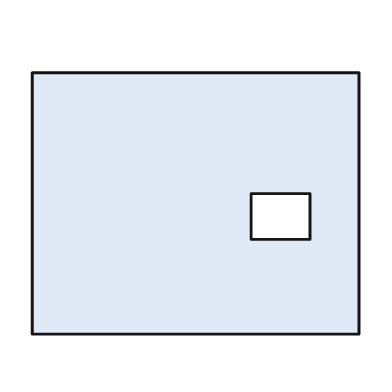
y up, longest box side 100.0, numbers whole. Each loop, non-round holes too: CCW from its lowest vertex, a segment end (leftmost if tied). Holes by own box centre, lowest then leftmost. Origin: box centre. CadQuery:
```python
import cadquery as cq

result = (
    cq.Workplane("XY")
    .moveTo(-50.0, -40.0)
    .lineTo(50.0, -40.0)
    .lineTo(50.0, 40.0)
    .lineTo(-50.0, 40.0)
    .close()
    .moveTo(17.0, -11.0)
    .lineTo(35.0, -11.0)
    .lineTo(35.0, 3.0)
    .lineTo(17.0, 3.0)
    .close()
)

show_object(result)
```